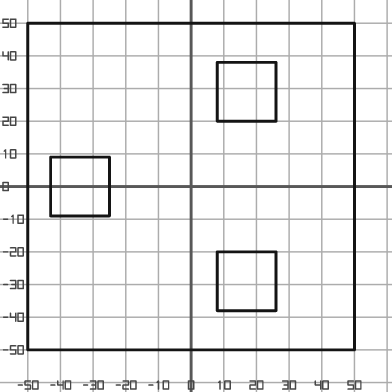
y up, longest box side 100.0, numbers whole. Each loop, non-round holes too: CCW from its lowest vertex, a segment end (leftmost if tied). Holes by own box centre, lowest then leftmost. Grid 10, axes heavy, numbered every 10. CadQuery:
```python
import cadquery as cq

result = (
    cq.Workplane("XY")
    .moveTo(-50.0, -50.0)
    .lineTo(50.0, -50.0)
    .lineTo(50.0, 50.0)
    .lineTo(-50.0, 50.0)
    .close()
    .moveTo(8.0, -38.0)
    .lineTo(26.0, -38.0)
    .lineTo(26.0, -20.0)
    .lineTo(8.0, -20.0)
    .close()
    .moveTo(-43.0, -9.0)
    .lineTo(-25.0, -9.0)
    .lineTo(-25.0, 9.0)
    .lineTo(-43.0, 9.0)
    .close()
    .moveTo(8.0, 20.0)
    .lineTo(26.0, 20.0)
    .lineTo(26.0, 38.0)
    .lineTo(8.0, 38.0)
    .close()
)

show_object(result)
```